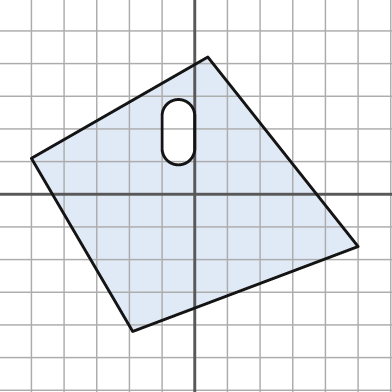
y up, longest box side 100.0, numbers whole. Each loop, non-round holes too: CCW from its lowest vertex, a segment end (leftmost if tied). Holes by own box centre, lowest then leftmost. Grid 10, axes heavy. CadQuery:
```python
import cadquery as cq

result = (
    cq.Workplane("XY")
    .moveTo(-19.0, -42.0)
    .lineTo(50.0, -16.0)
    .lineTo(4.0, 42.0)
    .lineTo(-50.0, 11.0)
    .close()
    .moveTo(-10.0, 14.0)
    .threePointArc((-5.0, 9.0), (0.0, 14.0))
    .lineTo(0.0, 24.0)
    .threePointArc((-5.0, 29.0), (-10.0, 24.0))
    .close()
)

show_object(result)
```